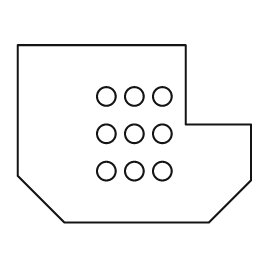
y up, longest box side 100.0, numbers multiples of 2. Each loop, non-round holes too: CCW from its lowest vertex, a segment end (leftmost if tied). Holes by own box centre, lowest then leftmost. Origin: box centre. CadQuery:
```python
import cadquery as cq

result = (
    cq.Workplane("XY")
    .moveTo(-30.0, -38.0)
    .lineTo(32.0, -38.0)
    .lineTo(50.0, -20.0)
    .lineTo(50.0, 4.0)
    .lineTo(22.0, 4.0)
    .lineTo(22.0, 38.0)
    .lineTo(-50.0, 38.0)
    .lineTo(-50.0, -18.0)
    .close()
    .moveTo(-12.0, -16.0)
    .circle(4.0)
    .moveTo(0.0, -16.0)
    .circle(4.0)
    .moveTo(12.0, -16.0)
    .circle(4.0)
    .moveTo(-12.0, 0.0)
    .circle(4.0)
    .moveTo(0.0, 0.0)
    .circle(4.0)
    .moveTo(12.0, 0.0)
    .circle(4.0)
    .moveTo(-12.0, 16.0)
    .circle(4.0)
    .moveTo(0.0, 16.0)
    .circle(4.0)
    .moveTo(12.0, 16.0)
    .circle(4.0)
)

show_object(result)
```